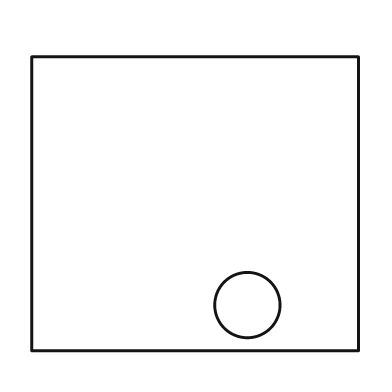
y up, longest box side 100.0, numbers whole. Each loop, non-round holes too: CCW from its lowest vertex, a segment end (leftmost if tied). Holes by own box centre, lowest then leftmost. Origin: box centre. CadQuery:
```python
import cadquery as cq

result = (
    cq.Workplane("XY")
    .moveTo(-50.0, -45.0)
    .lineTo(50.0, -45.0)
    .lineTo(50.0, 45.0)
    .lineTo(-50.0, 45.0)
    .close()
    .moveTo(16.0, -31.0)
    .circle(10.0)
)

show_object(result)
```